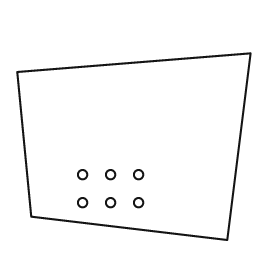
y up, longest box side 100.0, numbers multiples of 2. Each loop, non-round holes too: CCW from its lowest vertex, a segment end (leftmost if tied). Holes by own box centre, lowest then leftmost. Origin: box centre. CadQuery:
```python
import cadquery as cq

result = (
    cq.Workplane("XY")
    .moveTo(40.0, -40.0)
    .lineTo(50.0, 40.0)
    .lineTo(-50.0, 32.0)
    .lineTo(-44.0, -30.0)
    .close()
    .moveTo(-22.0, -24.0)
    .circle(2.0)
    .moveTo(-10.0, -24.0)
    .circle(2.0)
    .moveTo(2.0, -24.0)
    .circle(2.0)
    .moveTo(-22.0, -12.0)
    .circle(2.0)
    .moveTo(-10.0, -12.0)
    .circle(2.0)
    .moveTo(2.0, -12.0)
    .circle(2.0)
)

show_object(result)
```